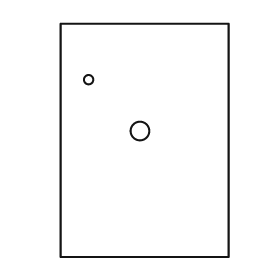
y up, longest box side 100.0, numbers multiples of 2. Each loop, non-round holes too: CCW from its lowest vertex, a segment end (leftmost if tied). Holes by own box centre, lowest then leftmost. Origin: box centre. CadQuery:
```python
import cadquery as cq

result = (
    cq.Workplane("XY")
    .moveTo(-36.0, -50.0)
    .lineTo(36.0, -50.0)
    .lineTo(36.0, 50.0)
    .lineTo(-36.0, 50.0)
    .close()
    .moveTo(-2.0, 4.0)
    .circle(4.0)
    .moveTo(-24.0, 26.0)
    .circle(2.0)
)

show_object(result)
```